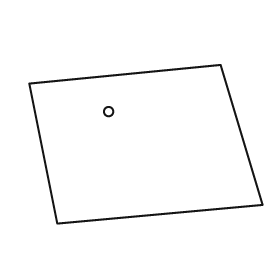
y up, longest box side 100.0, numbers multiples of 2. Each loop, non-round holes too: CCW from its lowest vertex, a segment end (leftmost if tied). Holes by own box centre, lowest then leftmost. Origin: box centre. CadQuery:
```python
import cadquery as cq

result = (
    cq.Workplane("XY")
    .moveTo(-38.0, -34.0)
    .lineTo(50.0, -26.0)
    .lineTo(32.0, 34.0)
    .lineTo(-50.0, 26.0)
    .close()
    .moveTo(-16.0, 14.0)
    .circle(2.0)
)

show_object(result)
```